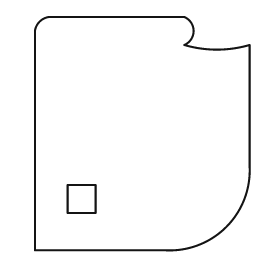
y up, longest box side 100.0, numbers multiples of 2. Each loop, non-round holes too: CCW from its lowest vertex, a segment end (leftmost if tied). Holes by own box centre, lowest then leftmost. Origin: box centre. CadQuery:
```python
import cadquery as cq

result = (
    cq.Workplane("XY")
    .moveTo(-46.0, -50.0)
    .lineTo(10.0, -50.0)
    .threePointArc((36.0, -40.0), (46.0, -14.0))
    .lineTo(46.0, 38.0)
    .threePointArc((32.0, 36.0), (18.0, 38.0))
    .threePointArc((22.0, 44.0), (18.0, 50.0))
    .lineTo(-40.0, 50.0)
    .threePointArc((-44.0, 48.0), (-46.0, 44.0))
    .close()
    .moveTo(-32.0, -34.0)
    .lineTo(-20.0, -34.0)
    .lineTo(-20.0, -22.0)
    .lineTo(-32.0, -22.0)
    .close()
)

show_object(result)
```